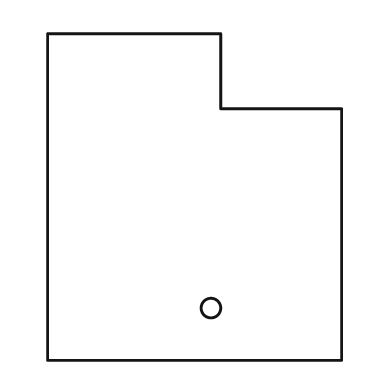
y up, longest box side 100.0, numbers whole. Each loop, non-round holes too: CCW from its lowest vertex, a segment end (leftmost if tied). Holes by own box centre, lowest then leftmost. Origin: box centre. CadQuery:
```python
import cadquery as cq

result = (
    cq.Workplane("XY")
    .moveTo(-45.0, -50.0)
    .lineTo(45.0, -50.0)
    .lineTo(45.0, 27.0)
    .lineTo(8.0, 27.0)
    .lineTo(8.0, 50.0)
    .lineTo(-45.0, 50.0)
    .close()
    .moveTo(5.0, -34.0)
    .circle(3.0)
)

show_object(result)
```